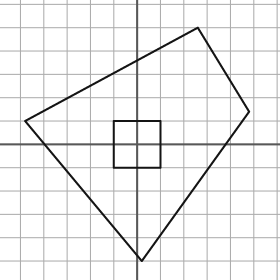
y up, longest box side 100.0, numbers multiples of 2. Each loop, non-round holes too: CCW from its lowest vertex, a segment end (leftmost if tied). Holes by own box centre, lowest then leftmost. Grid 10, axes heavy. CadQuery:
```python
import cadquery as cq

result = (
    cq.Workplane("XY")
    .moveTo(2.0, -50.0)
    .lineTo(48.0, 14.0)
    .lineTo(26.0, 50.0)
    .lineTo(-48.0, 10.0)
    .close()
    .moveTo(-10.0, -10.0)
    .lineTo(10.0, -10.0)
    .lineTo(10.0, 10.0)
    .lineTo(-10.0, 10.0)
    .close()
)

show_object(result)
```